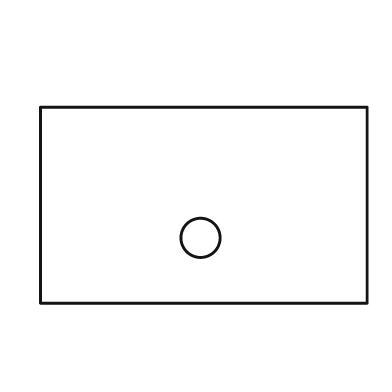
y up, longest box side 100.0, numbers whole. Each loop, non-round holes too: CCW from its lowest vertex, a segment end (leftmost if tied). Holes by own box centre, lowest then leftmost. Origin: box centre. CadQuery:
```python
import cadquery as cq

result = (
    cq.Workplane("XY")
    .moveTo(-50.0, -30.0)
    .lineTo(50.0, -30.0)
    .lineTo(50.0, 30.0)
    .lineTo(-50.0, 30.0)
    .close()
    .moveTo(-1.0, -10.0)
    .circle(6.0)
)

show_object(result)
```